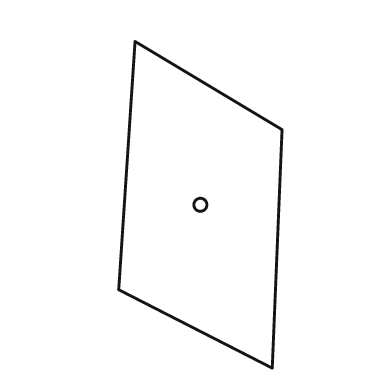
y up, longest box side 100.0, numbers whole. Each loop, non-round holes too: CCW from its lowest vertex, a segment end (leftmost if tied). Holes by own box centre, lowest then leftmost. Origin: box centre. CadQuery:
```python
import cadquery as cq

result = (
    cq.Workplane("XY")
    .moveTo(22.0, -50.0)
    .lineTo(25.0, 23.0)
    .lineTo(-20.0, 50.0)
    .lineTo(-25.0, -26.0)
    .close()
    .moveTo(0.0, 0.0)
    .circle(2.0)
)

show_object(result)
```